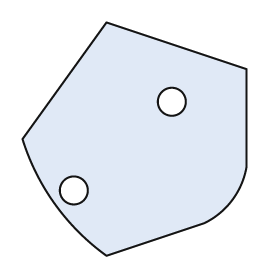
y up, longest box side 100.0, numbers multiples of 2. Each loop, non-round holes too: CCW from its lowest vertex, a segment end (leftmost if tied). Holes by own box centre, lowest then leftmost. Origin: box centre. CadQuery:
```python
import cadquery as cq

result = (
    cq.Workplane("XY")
    .moveTo(-12.0, -50.0)
    .lineTo(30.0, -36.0)
    .threePointArc((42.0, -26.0), (48.0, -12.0))
    .lineTo(48.0, 30.0)
    .lineTo(-12.0, 50.0)
    .lineTo(-48.0, 0.0)
    .threePointArc((-34.0, -28.0), (-12.0, -50.0))
    .close()
    .moveTo(-26.0, -22.0)
    .circle(6.0)
    .moveTo(16.0, 16.0)
    .circle(6.0)
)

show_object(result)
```